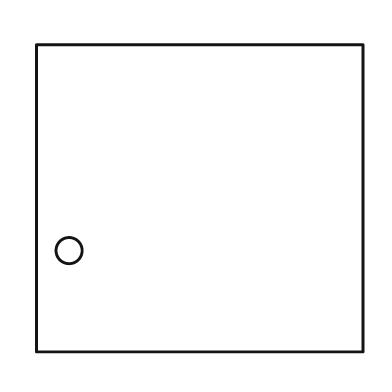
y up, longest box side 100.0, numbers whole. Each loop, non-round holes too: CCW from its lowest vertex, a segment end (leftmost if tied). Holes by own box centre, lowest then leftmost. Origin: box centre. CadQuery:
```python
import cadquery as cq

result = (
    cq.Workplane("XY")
    .moveTo(-50.0, -47.0)
    .lineTo(50.0, -47.0)
    .lineTo(50.0, 47.0)
    .lineTo(-50.0, 47.0)
    .close()
    .moveTo(-40.0, -16.0)
    .circle(4.0)
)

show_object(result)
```